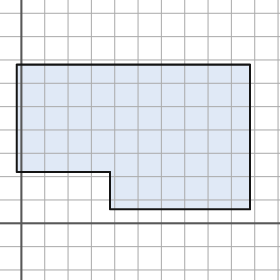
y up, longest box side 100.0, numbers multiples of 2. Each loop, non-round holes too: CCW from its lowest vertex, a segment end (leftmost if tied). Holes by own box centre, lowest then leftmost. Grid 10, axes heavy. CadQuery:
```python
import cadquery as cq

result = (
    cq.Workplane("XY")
    .moveTo(38.0, 6.0)
    .lineTo(98.0, 6.0)
    .lineTo(98.0, 68.0)
    .lineTo(-2.0, 68.0)
    .lineTo(-2.0, 22.0)
    .lineTo(38.0, 22.0)
    .close()
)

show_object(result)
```